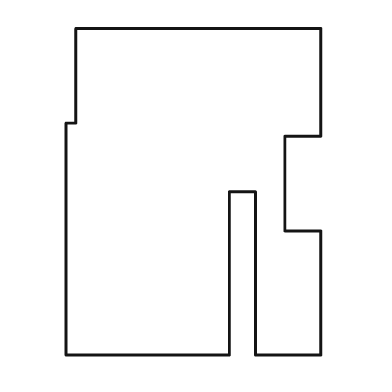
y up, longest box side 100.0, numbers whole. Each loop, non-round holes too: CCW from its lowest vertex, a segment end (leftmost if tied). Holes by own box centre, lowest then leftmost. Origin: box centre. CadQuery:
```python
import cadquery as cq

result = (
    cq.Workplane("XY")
    .moveTo(-39.0, -50.0)
    .lineTo(11.0, -50.0)
    .lineTo(11.0, 0.0)
    .lineTo(19.0, 0.0)
    .lineTo(19.0, -50.0)
    .lineTo(39.0, -50.0)
    .lineTo(39.0, -12.0)
    .lineTo(28.0, -12.0)
    .lineTo(28.0, 17.0)
    .lineTo(39.0, 17.0)
    .lineTo(39.0, 50.0)
    .lineTo(-36.0, 50.0)
    .lineTo(-36.0, 21.0)
    .lineTo(-39.0, 21.0)
    .close()
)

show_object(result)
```